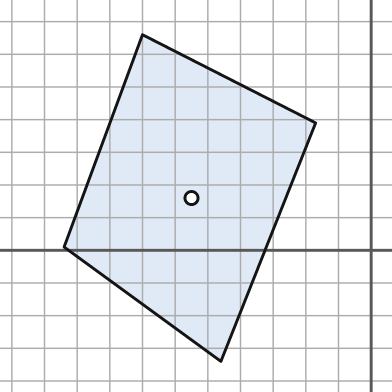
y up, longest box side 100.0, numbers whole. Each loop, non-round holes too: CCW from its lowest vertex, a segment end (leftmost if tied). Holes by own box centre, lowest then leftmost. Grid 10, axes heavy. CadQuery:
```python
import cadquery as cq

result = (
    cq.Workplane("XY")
    .moveTo(-46.0, -34.0)
    .lineTo(-17.0, 39.0)
    .lineTo(-70.0, 66.0)
    .lineTo(-94.0, 1.0)
    .close()
    .moveTo(-55.0, 16.0)
    .circle(2.0)
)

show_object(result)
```